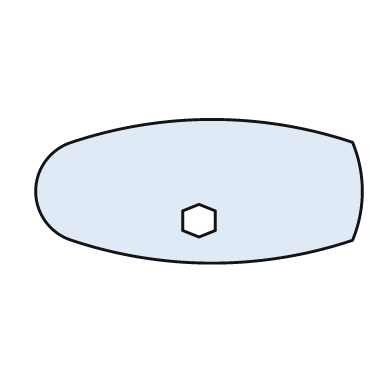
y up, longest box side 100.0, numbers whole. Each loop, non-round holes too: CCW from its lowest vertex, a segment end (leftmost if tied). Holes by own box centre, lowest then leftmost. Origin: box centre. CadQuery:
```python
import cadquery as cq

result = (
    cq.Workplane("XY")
    .moveTo(-39.0, -15.0)
    .threePointArc((4.0, -22.0), (47.0, -15.0))
    .threePointArc((50.0, 0.0), (47.0, 15.0))
    .threePointArc((4.0, 22.0), (-39.0, 15.0))
    .threePointArc((-50.0, 0.0), (-39.0, -15.0))
    .close()
    .moveTo(0.0, -14.0)
    .lineTo(5.0, -12.0)
    .lineTo(5.0, -6.0)
    .lineTo(0.0, -4.0)
    .lineTo(-5.0, -6.0)
    .lineTo(-5.0, -12.0)
    .close()
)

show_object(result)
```